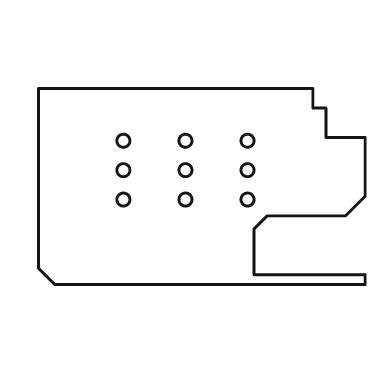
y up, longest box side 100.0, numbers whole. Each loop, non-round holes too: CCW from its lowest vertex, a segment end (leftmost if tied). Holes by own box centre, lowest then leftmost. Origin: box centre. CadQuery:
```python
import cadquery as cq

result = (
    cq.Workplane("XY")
    .moveTo(-45.0, -30.0)
    .lineTo(50.0, -30.0)
    .lineTo(50.0, -27.0)
    .lineTo(16.0, -27.0)
    .lineTo(16.0, -13.0)
    .lineTo(20.0, -9.0)
    .lineTo(44.0, -9.0)
    .lineTo(50.0, -3.0)
    .lineTo(50.0, 15.0)
    .lineTo(38.0, 15.0)
    .lineTo(38.0, 24.0)
    .lineTo(34.0, 24.0)
    .lineTo(34.0, 30.0)
    .lineTo(-50.0, 30.0)
    .lineTo(-50.0, -25.0)
    .close()
    .moveTo(-24.0, -4.0)
    .circle(2.0)
    .moveTo(-5.0, -4.0)
    .circle(2.0)
    .moveTo(14.0, -4.0)
    .circle(2.0)
    .moveTo(-24.0, 5.0)
    .circle(2.0)
    .moveTo(-5.0, 5.0)
    .circle(2.0)
    .moveTo(14.0, 5.0)
    .circle(2.0)
    .moveTo(-24.0, 14.0)
    .circle(2.0)
    .moveTo(-5.0, 14.0)
    .circle(2.0)
    .moveTo(14.0, 14.0)
    .circle(2.0)
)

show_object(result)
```